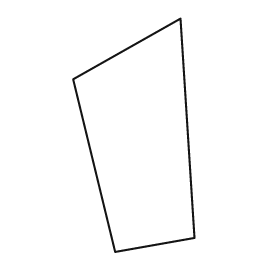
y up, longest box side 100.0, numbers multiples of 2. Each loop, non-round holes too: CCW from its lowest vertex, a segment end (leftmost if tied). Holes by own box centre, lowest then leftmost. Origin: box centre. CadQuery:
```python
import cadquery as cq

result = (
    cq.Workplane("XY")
    .moveTo(-8.0, -50.0)
    .lineTo(26.0, -44.0)
    .lineTo(20.0, 50.0)
    .lineTo(-26.0, 24.0)
    .close()
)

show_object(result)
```